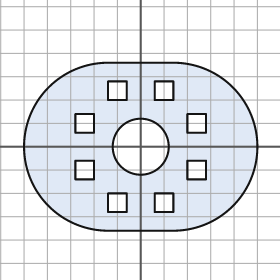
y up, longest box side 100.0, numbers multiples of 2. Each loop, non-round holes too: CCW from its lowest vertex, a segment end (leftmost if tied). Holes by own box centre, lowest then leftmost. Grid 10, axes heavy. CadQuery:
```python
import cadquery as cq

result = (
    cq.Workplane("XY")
    .moveTo(-14.0, -36.0)
    .lineTo(14.0, -36.0)
    .threePointArc((50.0, 0.0), (14.0, 36.0))
    .lineTo(-14.0, 36.0)
    .threePointArc((-50.0, 0.0), (-14.0, -36.0))
    .close()
    .moveTo(-14.0, -28.0)
    .lineTo(-6.0, -28.0)
    .lineTo(-6.0, -20.0)
    .lineTo(-14.0, -20.0)
    .close()
    .moveTo(6.0, -28.0)
    .lineTo(14.0, -28.0)
    .lineTo(14.0, -20.0)
    .lineTo(6.0, -20.0)
    .close()
    .moveTo(-28.0, -14.0)
    .lineTo(-20.0, -14.0)
    .lineTo(-20.0, -6.0)
    .lineTo(-28.0, -6.0)
    .close()
    .moveTo(20.0, -14.0)
    .lineTo(28.0, -14.0)
    .lineTo(28.0, -6.0)
    .lineTo(20.0, -6.0)
    .close()
    .moveTo(0.0, 0.0)
    .circle(12.0)
    .moveTo(-28.0, 6.0)
    .lineTo(-20.0, 6.0)
    .lineTo(-20.0, 14.0)
    .lineTo(-28.0, 14.0)
    .close()
    .moveTo(20.0, 6.0)
    .lineTo(28.0, 6.0)
    .lineTo(28.0, 14.0)
    .lineTo(20.0, 14.0)
    .close()
    .moveTo(-14.0, 20.0)
    .lineTo(-6.0, 20.0)
    .lineTo(-6.0, 28.0)
    .lineTo(-14.0, 28.0)
    .close()
    .moveTo(6.0, 20.0)
    .lineTo(14.0, 20.0)
    .lineTo(14.0, 28.0)
    .lineTo(6.0, 28.0)
    .close()
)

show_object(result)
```